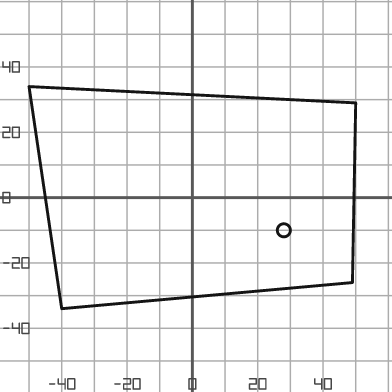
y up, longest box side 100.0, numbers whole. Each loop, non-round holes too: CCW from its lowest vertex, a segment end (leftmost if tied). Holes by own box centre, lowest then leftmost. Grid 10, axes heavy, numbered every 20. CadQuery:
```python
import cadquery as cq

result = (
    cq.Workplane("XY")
    .moveTo(-40.0, -34.0)
    .lineTo(49.0, -26.0)
    .lineTo(50.0, 29.0)
    .lineTo(-50.0, 34.0)
    .close()
    .moveTo(28.0, -10.0)
    .circle(2.0)
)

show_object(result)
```